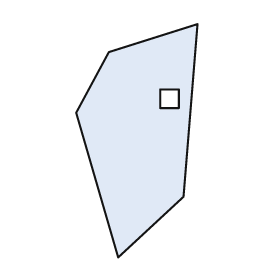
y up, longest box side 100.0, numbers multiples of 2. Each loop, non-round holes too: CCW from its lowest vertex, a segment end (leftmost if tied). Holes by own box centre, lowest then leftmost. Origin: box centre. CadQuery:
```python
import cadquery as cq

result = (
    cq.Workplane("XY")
    .moveTo(-8.0, -50.0)
    .lineTo(20.0, -24.0)
    .lineTo(26.0, 50.0)
    .lineTo(-12.0, 38.0)
    .lineTo(-26.0, 12.0)
    .close()
    .moveTo(10.0, 14.0)
    .lineTo(18.0, 14.0)
    .lineTo(18.0, 22.0)
    .lineTo(10.0, 22.0)
    .close()
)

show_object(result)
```